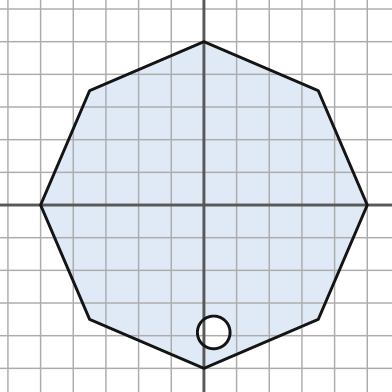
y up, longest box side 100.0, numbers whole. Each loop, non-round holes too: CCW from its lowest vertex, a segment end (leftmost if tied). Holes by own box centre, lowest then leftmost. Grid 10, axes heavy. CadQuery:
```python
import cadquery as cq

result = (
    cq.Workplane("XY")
    .moveTo(0.0, -50.0)
    .lineTo(35.0, -35.0)
    .lineTo(50.0, 0.0)
    .lineTo(35.0, 35.0)
    .lineTo(0.0, 50.0)
    .lineTo(-35.0, 35.0)
    .lineTo(-50.0, 0.0)
    .lineTo(-35.0, -35.0)
    .close()
    .moveTo(3.0, -39.0)
    .circle(5.0)
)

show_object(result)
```